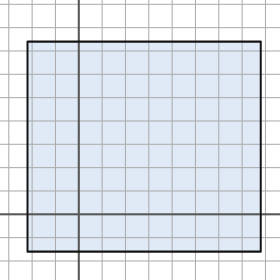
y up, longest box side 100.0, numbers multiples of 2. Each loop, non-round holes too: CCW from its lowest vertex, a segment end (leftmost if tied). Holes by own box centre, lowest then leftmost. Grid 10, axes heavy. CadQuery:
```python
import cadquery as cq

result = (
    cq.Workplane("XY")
    .moveTo(-22.0, -16.0)
    .lineTo(78.0, -16.0)
    .lineTo(78.0, 74.0)
    .lineTo(-22.0, 74.0)
    .close()
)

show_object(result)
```